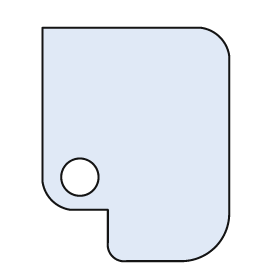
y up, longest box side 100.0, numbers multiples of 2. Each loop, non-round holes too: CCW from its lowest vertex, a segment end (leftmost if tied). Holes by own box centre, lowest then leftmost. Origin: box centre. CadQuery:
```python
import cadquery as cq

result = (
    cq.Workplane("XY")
    .moveTo(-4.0, -50.0)
    .lineTo(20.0, -50.0)
    .threePointArc((34.0, -44.0), (40.0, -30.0))
    .lineTo(40.0, 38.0)
    .threePointArc((36.0, 46.0), (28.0, 50.0))
    .lineTo(-40.0, 50.0)
    .lineTo(-40.0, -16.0)
    .threePointArc((-36.0, -24.0), (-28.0, -28.0))
    .lineTo(-12.0, -28.0)
    .lineTo(-12.0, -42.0)
    .threePointArc((-10.0, -48.0), (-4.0, -50.0))
    .close()
    .moveTo(-24.0, -14.0)
    .circle(8.0)
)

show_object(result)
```